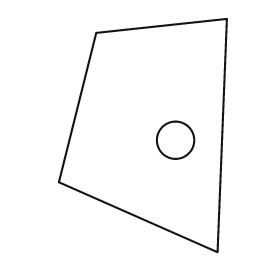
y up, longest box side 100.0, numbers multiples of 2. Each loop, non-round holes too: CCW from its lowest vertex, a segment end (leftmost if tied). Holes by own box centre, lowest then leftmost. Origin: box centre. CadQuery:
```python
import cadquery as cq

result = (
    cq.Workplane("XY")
    .moveTo(32.0, -50.0)
    .lineTo(36.0, 50.0)
    .lineTo(-20.0, 44.0)
    .lineTo(-36.0, -20.0)
    .close()
    .moveTo(14.0, -2.0)
    .circle(8.0)
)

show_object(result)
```